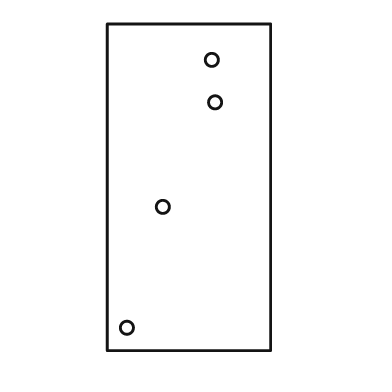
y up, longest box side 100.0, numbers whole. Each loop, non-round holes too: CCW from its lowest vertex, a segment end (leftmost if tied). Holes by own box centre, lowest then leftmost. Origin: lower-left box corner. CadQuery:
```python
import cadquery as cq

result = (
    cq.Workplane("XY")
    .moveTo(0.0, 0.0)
    .lineTo(50.0, 0.0)
    .lineTo(50.0, 100.0)
    .lineTo(0.0, 100.0)
    .close()
    .moveTo(6.0, 7.0)
    .circle(2.0)
    .moveTo(17.0, 44.0)
    .circle(2.0)
    .moveTo(33.0, 76.0)
    .circle(2.0)
    .moveTo(32.0, 89.0)
    .circle(2.0)
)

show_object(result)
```